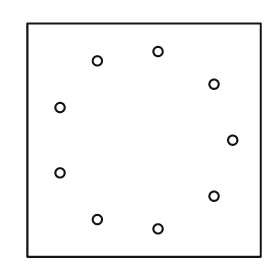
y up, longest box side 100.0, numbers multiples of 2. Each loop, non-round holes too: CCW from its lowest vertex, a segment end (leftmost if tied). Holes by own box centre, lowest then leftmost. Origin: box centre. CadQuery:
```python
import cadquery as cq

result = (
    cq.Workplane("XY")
    .moveTo(-50.0, -50.0)
    .lineTo(50.0, -50.0)
    .lineTo(50.0, 50.0)
    .lineTo(-50.0, 50.0)
    .close()
    .moveTo(6.0, -38.0)
    .circle(2.0)
    .moveTo(-20.0, -34.0)
    .circle(2.0)
    .moveTo(30.0, -24.0)
    .circle(2.0)
    .moveTo(-36.0, -14.0)
    .circle(2.0)
    .moveTo(38.0, 0.0)
    .circle(2.0)
    .moveTo(-36.0, 14.0)
    .circle(2.0)
    .moveTo(30.0, 24.0)
    .circle(2.0)
    .moveTo(-20.0, 34.0)
    .circle(2.0)
    .moveTo(6.0, 38.0)
    .circle(2.0)
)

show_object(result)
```